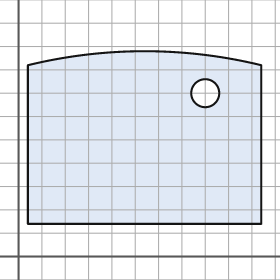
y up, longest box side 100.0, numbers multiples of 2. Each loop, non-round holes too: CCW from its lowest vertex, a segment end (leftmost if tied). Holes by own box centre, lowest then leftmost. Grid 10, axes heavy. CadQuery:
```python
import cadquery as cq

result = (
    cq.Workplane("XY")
    .moveTo(4.0, 14.0)
    .lineTo(104.0, 14.0)
    .lineTo(104.0, 82.0)
    .threePointArc((54.0, 88.0), (4.0, 82.0))
    .close()
    .moveTo(80.0, 70.0)
    .circle(6.0)
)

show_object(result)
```